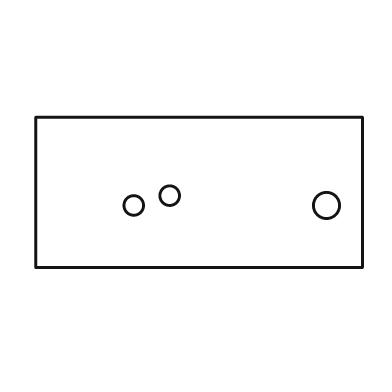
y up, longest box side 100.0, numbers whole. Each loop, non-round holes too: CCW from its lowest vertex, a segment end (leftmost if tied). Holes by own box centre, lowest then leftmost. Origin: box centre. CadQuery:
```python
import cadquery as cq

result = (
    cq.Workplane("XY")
    .moveTo(-50.0, -23.0)
    .lineTo(50.0, -23.0)
    .lineTo(50.0, 23.0)
    .lineTo(-50.0, 23.0)
    .close()
    .moveTo(-20.0, -4.0)
    .circle(3.0)
    .moveTo(39.0, -4.0)
    .circle(4.0)
    .moveTo(-9.0, -1.0)
    .circle(3.0)
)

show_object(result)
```